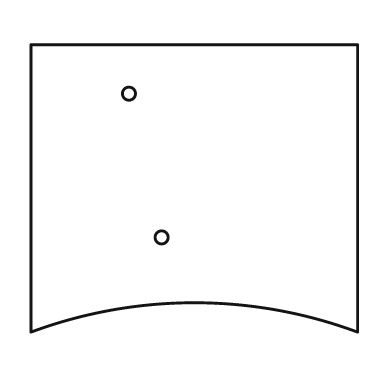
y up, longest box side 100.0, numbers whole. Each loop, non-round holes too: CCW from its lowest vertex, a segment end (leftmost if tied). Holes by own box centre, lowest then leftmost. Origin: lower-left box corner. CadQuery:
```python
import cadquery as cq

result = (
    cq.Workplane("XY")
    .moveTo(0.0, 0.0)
    .threePointArc((50.0, 9.0), (100.0, 0.0))
    .lineTo(100.0, 88.0)
    .lineTo(0.0, 88.0)
    .close()
    .moveTo(40.0, 29.0)
    .circle(2.0)
    .moveTo(30.0, 73.0)
    .circle(2.0)
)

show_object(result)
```